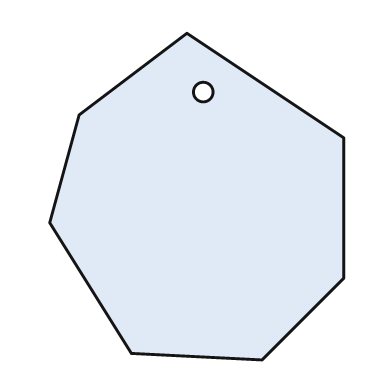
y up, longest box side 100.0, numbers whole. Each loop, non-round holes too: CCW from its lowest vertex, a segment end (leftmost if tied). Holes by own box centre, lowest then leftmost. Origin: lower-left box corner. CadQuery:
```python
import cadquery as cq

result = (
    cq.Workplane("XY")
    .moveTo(65.0, 0.0)
    .lineTo(90.0, 25.0)
    .lineTo(90.0, 68.0)
    .lineTo(42.0, 100.0)
    .lineTo(9.0, 75.0)
    .lineTo(0.0, 42.0)
    .lineTo(25.0, 2.0)
    .close()
    .moveTo(47.0, 82.0)
    .circle(3.0)
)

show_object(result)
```